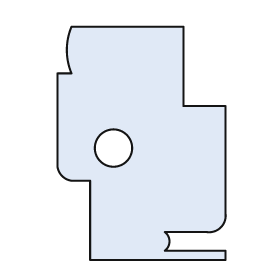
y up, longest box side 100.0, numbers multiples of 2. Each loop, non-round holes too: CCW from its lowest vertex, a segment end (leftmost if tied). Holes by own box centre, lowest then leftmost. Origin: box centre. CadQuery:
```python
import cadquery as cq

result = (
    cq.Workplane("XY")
    .moveTo(-22.0, -50.0)
    .lineTo(36.0, -50.0)
    .lineTo(36.0, -46.0)
    .lineTo(10.0, -46.0)
    .threePointArc((12.0, -42.0), (10.0, -38.0))
    .lineTo(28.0, -38.0)
    .threePointArc((34.0, -36.0), (36.0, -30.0))
    .lineTo(36.0, 16.0)
    .lineTo(18.0, 16.0)
    .lineTo(18.0, 50.0)
    .lineTo(-30.0, 50.0)
    .threePointArc((-32.0, 40.0), (-30.0, 30.0))
    .lineTo(-36.0, 30.0)
    .lineTo(-36.0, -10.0)
    .threePointArc((-34.0, -14.0), (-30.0, -16.0))
    .lineTo(-22.0, -16.0)
    .close()
    .moveTo(-12.0, -2.0)
    .circle(8.0)
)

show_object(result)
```